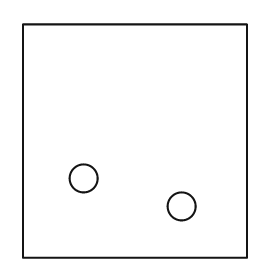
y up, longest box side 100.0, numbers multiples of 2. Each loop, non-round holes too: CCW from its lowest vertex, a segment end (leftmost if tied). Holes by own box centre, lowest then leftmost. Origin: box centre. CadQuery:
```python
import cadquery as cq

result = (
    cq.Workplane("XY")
    .moveTo(-48.0, -50.0)
    .lineTo(48.0, -50.0)
    .lineTo(48.0, 50.0)
    .lineTo(-48.0, 50.0)
    .close()
    .moveTo(20.0, -28.0)
    .circle(6.0)
    .moveTo(-22.0, -16.0)
    .circle(6.0)
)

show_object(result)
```